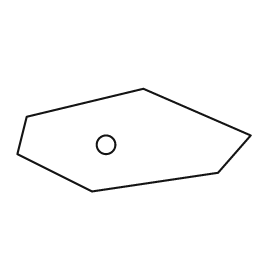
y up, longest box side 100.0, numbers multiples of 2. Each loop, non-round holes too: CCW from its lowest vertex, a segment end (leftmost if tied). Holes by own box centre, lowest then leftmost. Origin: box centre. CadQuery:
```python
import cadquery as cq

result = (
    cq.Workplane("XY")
    .moveTo(-18.0, -22.0)
    .lineTo(36.0, -14.0)
    .lineTo(50.0, 2.0)
    .lineTo(4.0, 22.0)
    .lineTo(-46.0, 10.0)
    .lineTo(-50.0, -6.0)
    .close()
    .moveTo(-12.0, -2.0)
    .circle(4.0)
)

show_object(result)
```